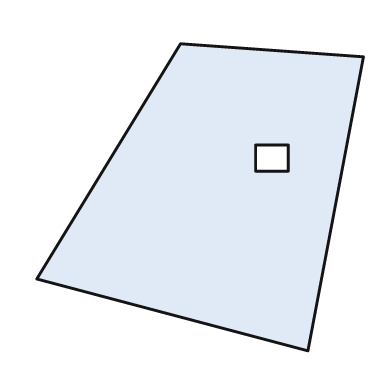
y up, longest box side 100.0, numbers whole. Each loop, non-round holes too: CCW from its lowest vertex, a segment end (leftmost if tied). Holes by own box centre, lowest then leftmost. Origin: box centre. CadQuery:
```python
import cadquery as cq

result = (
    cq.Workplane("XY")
    .moveTo(33.0, -47.0)
    .lineTo(50.0, 43.0)
    .lineTo(-6.0, 47.0)
    .lineTo(-50.0, -25.0)
    .close()
    .moveTo(17.0, 8.0)
    .lineTo(27.0, 8.0)
    .lineTo(27.0, 16.0)
    .lineTo(17.0, 16.0)
    .close()
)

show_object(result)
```